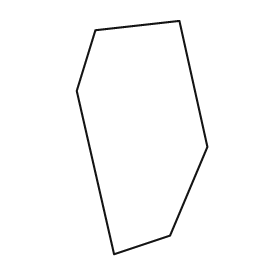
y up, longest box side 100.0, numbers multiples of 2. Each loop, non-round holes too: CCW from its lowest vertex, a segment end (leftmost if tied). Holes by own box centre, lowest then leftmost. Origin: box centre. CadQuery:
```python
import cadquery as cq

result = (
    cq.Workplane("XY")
    .moveTo(-12.0, -50.0)
    .lineTo(12.0, -42.0)
    .lineTo(28.0, -4.0)
    .lineTo(16.0, 50.0)
    .lineTo(-20.0, 46.0)
    .lineTo(-28.0, 20.0)
    .close()
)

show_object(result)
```